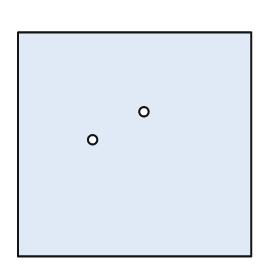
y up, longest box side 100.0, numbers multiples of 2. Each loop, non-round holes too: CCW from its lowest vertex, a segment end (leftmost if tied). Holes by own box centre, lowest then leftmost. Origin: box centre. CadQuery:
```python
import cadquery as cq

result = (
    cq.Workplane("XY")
    .moveTo(-50.0, -48.0)
    .lineTo(50.0, -48.0)
    .lineTo(50.0, 48.0)
    .lineTo(-50.0, 48.0)
    .close()
    .moveTo(-18.0, 2.0)
    .circle(2.0)
    .moveTo(4.0, 14.0)
    .circle(2.0)
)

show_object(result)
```